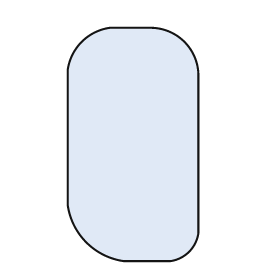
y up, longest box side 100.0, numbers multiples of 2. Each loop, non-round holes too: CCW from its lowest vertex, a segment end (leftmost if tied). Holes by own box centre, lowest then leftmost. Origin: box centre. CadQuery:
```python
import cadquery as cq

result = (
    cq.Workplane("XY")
    .moveTo(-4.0, -50.0)
    .lineTo(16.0, -50.0)
    .threePointArc((24.0, -46.0), (28.0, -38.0))
    .lineTo(28.0, 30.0)
    .threePointArc((22.0, 44.0), (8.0, 50.0))
    .lineTo(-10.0, 50.0)
    .threePointArc((-22.0, 44.0), (-28.0, 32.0))
    .lineTo(-28.0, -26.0)
    .threePointArc((-20.0, -42.0), (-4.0, -50.0))
    .close()
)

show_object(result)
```